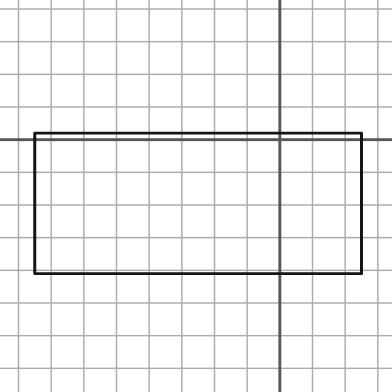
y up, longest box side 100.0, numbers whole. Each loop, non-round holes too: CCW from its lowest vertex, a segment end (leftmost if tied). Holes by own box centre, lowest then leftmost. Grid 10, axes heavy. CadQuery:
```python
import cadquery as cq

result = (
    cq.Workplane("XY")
    .moveTo(-75.0, -41.0)
    .lineTo(25.0, -41.0)
    .lineTo(25.0, 2.0)
    .lineTo(-75.0, 2.0)
    .close()
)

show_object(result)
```